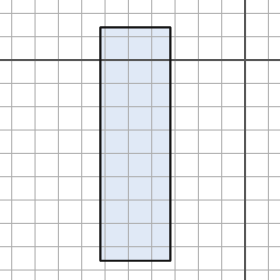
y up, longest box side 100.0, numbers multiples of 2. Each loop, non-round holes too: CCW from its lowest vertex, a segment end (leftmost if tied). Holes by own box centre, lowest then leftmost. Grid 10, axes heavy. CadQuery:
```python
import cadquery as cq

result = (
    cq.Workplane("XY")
    .moveTo(-62.0, -86.0)
    .lineTo(-32.0, -86.0)
    .lineTo(-32.0, 14.0)
    .lineTo(-62.0, 14.0)
    .close()
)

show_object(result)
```